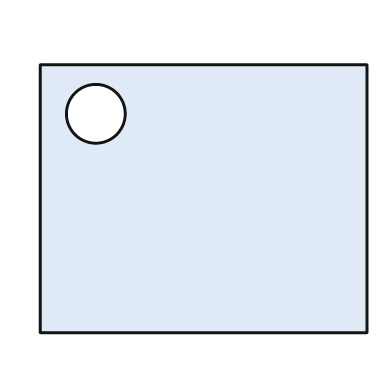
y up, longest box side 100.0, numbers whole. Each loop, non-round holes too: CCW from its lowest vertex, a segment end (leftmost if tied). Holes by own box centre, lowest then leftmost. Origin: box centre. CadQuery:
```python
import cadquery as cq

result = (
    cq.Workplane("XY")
    .moveTo(-50.0, -41.0)
    .lineTo(50.0, -41.0)
    .lineTo(50.0, 41.0)
    .lineTo(-50.0, 41.0)
    .close()
    .moveTo(-33.0, 26.0)
    .circle(9.0)
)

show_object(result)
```